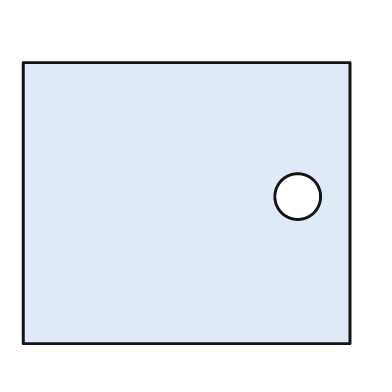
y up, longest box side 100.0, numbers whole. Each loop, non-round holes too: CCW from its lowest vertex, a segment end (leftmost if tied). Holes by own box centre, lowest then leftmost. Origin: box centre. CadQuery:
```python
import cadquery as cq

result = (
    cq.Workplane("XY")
    .moveTo(-50.0, -43.0)
    .lineTo(50.0, -43.0)
    .lineTo(50.0, 43.0)
    .lineTo(-50.0, 43.0)
    .close()
    .moveTo(34.0, 2.0)
    .circle(7.0)
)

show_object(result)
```